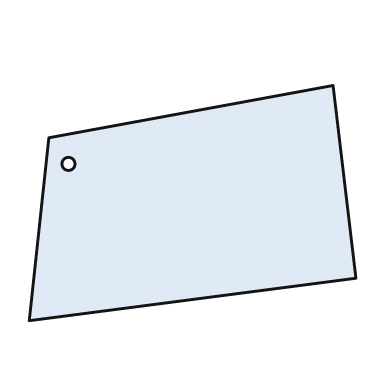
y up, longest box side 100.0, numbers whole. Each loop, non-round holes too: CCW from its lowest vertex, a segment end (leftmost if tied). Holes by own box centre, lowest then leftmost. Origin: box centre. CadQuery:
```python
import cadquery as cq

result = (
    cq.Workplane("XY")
    .moveTo(-50.0, -36.0)
    .lineTo(50.0, -23.0)
    .lineTo(43.0, 36.0)
    .lineTo(-44.0, 20.0)
    .close()
    .moveTo(-38.0, 12.0)
    .circle(2.0)
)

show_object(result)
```